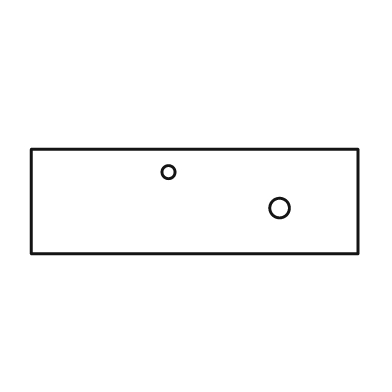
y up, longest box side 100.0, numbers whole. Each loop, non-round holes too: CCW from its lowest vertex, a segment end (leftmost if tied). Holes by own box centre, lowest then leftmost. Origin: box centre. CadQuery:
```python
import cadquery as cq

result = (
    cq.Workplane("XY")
    .moveTo(-50.0, -16.0)
    .lineTo(50.0, -16.0)
    .lineTo(50.0, 16.0)
    .lineTo(-50.0, 16.0)
    .close()
    .moveTo(26.0, -2.0)
    .circle(3.0)
    .moveTo(-8.0, 9.0)
    .circle(2.0)
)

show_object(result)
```